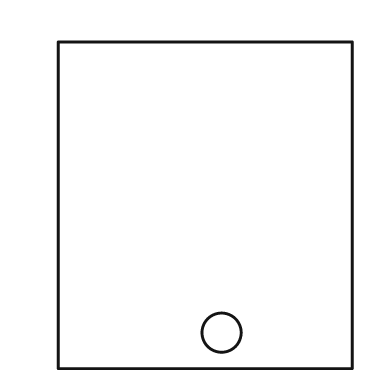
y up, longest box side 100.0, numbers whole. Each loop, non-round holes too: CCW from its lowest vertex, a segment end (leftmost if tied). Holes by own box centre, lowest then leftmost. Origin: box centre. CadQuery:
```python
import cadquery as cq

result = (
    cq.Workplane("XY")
    .moveTo(-45.0, -50.0)
    .lineTo(45.0, -50.0)
    .lineTo(45.0, 50.0)
    .lineTo(-45.0, 50.0)
    .close()
    .moveTo(5.0, -39.0)
    .circle(6.0)
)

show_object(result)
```